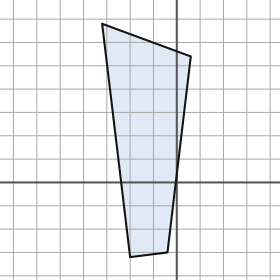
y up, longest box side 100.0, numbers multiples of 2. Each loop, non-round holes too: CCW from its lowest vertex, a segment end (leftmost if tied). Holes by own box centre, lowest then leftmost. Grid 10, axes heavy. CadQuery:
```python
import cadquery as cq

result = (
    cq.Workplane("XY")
    .moveTo(-20.0, -32.0)
    .lineTo(-4.0, -30.0)
    .lineTo(6.0, 54.0)
    .lineTo(-32.0, 68.0)
    .close()
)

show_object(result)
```